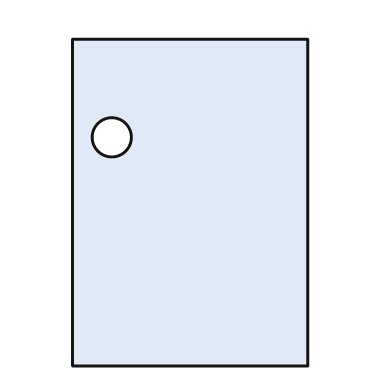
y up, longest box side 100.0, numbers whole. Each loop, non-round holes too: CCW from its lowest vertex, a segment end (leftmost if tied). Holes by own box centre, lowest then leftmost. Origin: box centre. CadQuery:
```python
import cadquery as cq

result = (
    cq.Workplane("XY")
    .moveTo(-36.0, -50.0)
    .lineTo(36.0, -50.0)
    .lineTo(36.0, 50.0)
    .lineTo(-36.0, 50.0)
    .close()
    .moveTo(-24.0, 20.0)
    .circle(6.0)
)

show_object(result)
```